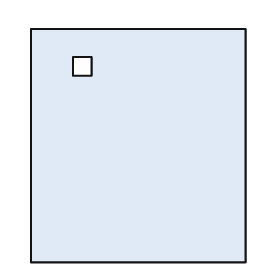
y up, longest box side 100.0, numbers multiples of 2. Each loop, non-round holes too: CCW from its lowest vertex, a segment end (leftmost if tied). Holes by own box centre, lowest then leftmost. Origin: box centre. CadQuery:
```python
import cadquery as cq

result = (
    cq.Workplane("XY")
    .moveTo(-46.0, -50.0)
    .lineTo(46.0, -50.0)
    .lineTo(46.0, 50.0)
    .lineTo(-46.0, 50.0)
    .close()
    .moveTo(-28.0, 30.0)
    .lineTo(-20.0, 30.0)
    .lineTo(-20.0, 38.0)
    .lineTo(-28.0, 38.0)
    .close()
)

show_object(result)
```